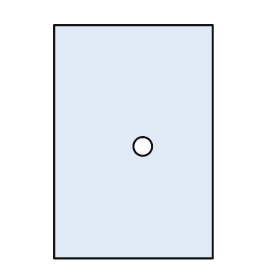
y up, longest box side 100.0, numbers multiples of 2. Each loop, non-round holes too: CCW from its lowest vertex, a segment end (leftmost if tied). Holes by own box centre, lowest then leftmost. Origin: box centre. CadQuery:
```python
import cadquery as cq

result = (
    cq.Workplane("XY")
    .moveTo(-34.0, -50.0)
    .lineTo(34.0, -50.0)
    .lineTo(34.0, 50.0)
    .lineTo(-34.0, 50.0)
    .close()
    .moveTo(4.0, -2.0)
    .circle(4.0)
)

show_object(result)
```